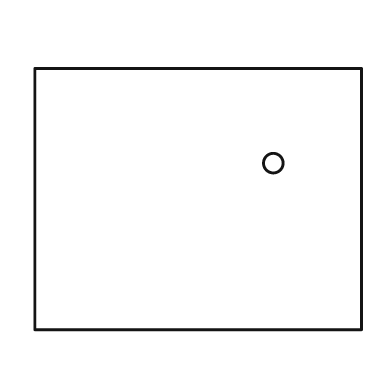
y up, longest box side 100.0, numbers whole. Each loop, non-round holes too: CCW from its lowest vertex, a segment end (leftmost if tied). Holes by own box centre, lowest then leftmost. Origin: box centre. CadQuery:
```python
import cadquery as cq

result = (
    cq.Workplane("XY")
    .moveTo(-50.0, -40.0)
    .lineTo(50.0, -40.0)
    .lineTo(50.0, 40.0)
    .lineTo(-50.0, 40.0)
    .close()
    .moveTo(23.0, 11.0)
    .circle(3.0)
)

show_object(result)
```